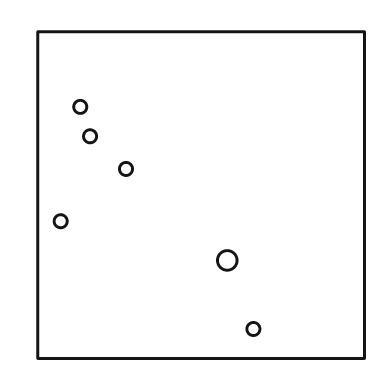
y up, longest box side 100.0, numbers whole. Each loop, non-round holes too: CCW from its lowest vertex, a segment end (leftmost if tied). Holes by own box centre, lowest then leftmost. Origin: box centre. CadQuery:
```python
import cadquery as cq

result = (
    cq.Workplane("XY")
    .moveTo(-50.0, -50.0)
    .lineTo(50.0, -50.0)
    .lineTo(50.0, 50.0)
    .lineTo(-50.0, 50.0)
    .close()
    .moveTo(16.0, -41.0)
    .circle(2.0)
    .moveTo(8.0, -20.0)
    .circle(3.0)
    .moveTo(-43.0, -8.0)
    .circle(2.0)
    .moveTo(-23.0, 8.0)
    .circle(2.0)
    .moveTo(-34.0, 18.0)
    .circle(2.0)
    .moveTo(-37.0, 27.0)
    .circle(2.0)
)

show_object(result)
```